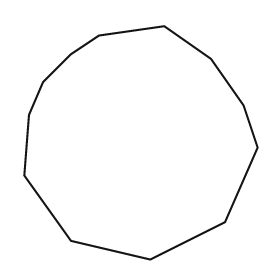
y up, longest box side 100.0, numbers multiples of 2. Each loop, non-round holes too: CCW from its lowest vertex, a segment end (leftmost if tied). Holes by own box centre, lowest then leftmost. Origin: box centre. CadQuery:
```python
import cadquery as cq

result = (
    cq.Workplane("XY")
    .moveTo(4.0, -50.0)
    .lineTo(36.0, -34.0)
    .lineTo(50.0, -2.0)
    .lineTo(44.0, 16.0)
    .lineTo(30.0, 36.0)
    .lineTo(10.0, 50.0)
    .lineTo(-18.0, 46.0)
    .lineTo(-30.0, 38.0)
    .lineTo(-42.0, 26.0)
    .lineTo(-48.0, 12.0)
    .lineTo(-50.0, -14.0)
    .lineTo(-30.0, -42.0)
    .close()
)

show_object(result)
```